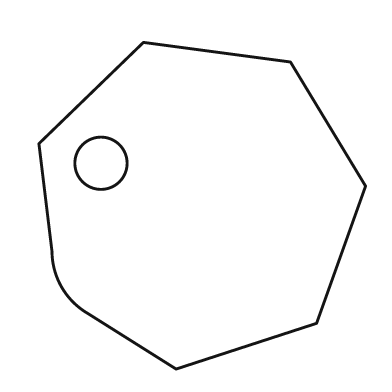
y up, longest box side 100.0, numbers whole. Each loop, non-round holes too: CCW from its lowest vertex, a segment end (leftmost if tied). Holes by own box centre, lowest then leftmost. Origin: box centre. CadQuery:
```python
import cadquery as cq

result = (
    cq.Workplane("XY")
    .moveTo(-8.0, -50.0)
    .lineTo(35.0, -36.0)
    .lineTo(50.0, 6.0)
    .lineTo(27.0, 44.0)
    .lineTo(-18.0, 50.0)
    .lineTo(-50.0, 19.0)
    .lineTo(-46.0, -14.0)
    .threePointArc((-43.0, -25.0), (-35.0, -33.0))
    .close()
    .moveTo(-31.0, 13.0)
    .circle(8.0)
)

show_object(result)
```